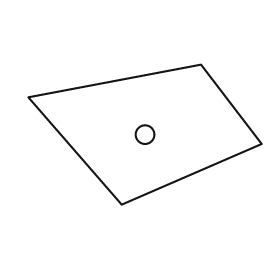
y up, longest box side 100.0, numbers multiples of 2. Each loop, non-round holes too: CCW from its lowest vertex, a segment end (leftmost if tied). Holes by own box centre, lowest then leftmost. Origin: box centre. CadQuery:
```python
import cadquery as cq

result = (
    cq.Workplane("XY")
    .moveTo(-10.0, -30.0)
    .lineTo(50.0, -4.0)
    .lineTo(24.0, 30.0)
    .lineTo(-50.0, 16.0)
    .close()
    .moveTo(0.0, 0.0)
    .circle(4.0)
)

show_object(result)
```